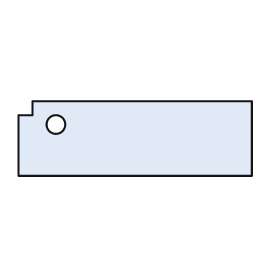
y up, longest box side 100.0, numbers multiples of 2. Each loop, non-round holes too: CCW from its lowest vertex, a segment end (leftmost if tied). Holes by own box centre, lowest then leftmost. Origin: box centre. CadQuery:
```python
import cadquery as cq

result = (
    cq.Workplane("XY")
    .moveTo(-50.0, -16.0)
    .lineTo(50.0, -16.0)
    .lineTo(50.0, 16.0)
    .lineTo(-44.0, 16.0)
    .lineTo(-44.0, 10.0)
    .lineTo(-50.0, 10.0)
    .close()
    .moveTo(-34.0, 6.0)
    .circle(4.0)
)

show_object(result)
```